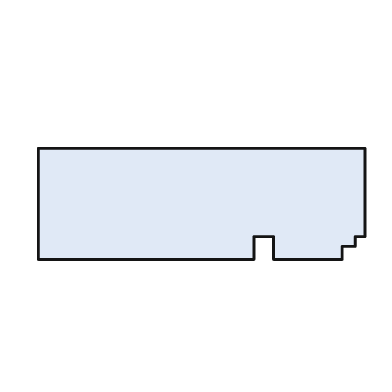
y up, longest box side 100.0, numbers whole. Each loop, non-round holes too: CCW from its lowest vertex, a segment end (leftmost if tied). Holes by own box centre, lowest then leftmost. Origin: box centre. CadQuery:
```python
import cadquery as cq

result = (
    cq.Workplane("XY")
    .moveTo(-50.0, -17.0)
    .lineTo(16.0, -17.0)
    .lineTo(16.0, -10.0)
    .lineTo(22.0, -10.0)
    .lineTo(22.0, -17.0)
    .lineTo(43.0, -17.0)
    .lineTo(43.0, -13.0)
    .lineTo(47.0, -13.0)
    .lineTo(47.0, -10.0)
    .lineTo(50.0, -10.0)
    .lineTo(50.0, 17.0)
    .lineTo(-50.0, 17.0)
    .close()
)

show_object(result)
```